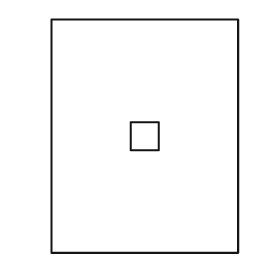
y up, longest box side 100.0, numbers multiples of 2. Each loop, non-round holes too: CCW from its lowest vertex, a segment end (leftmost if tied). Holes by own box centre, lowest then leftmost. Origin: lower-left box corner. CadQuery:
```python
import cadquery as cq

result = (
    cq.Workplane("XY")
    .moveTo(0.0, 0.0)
    .lineTo(80.0, 0.0)
    .lineTo(80.0, 100.0)
    .lineTo(0.0, 100.0)
    .close()
    .moveTo(34.0, 44.0)
    .lineTo(46.0, 44.0)
    .lineTo(46.0, 56.0)
    .lineTo(34.0, 56.0)
    .close()
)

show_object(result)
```